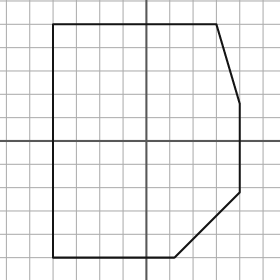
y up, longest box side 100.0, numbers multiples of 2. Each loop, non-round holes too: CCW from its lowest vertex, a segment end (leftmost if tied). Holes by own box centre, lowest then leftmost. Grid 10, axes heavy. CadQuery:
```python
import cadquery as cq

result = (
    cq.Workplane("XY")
    .moveTo(-40.0, -50.0)
    .lineTo(12.0, -50.0)
    .lineTo(40.0, -22.0)
    .lineTo(40.0, 16.0)
    .lineTo(30.0, 50.0)
    .lineTo(-40.0, 50.0)
    .close()
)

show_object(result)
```